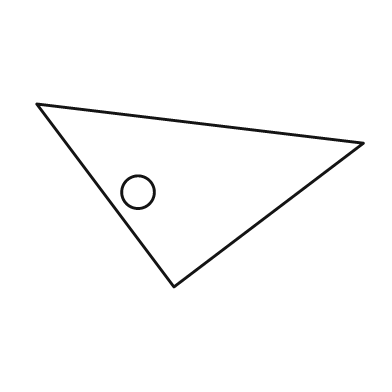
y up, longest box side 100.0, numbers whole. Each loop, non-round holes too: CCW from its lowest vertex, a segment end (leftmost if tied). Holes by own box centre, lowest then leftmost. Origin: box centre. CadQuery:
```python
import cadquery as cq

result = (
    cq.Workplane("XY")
    .moveTo(-8.0, -28.0)
    .lineTo(50.0, 16.0)
    .lineTo(-50.0, 28.0)
    .close()
    .moveTo(-19.0, 1.0)
    .circle(5.0)
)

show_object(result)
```